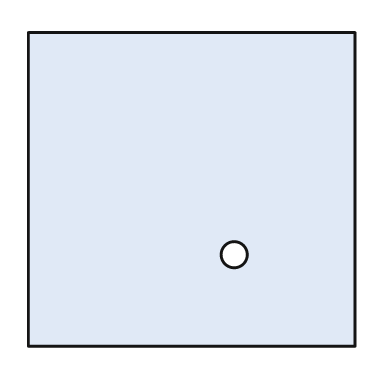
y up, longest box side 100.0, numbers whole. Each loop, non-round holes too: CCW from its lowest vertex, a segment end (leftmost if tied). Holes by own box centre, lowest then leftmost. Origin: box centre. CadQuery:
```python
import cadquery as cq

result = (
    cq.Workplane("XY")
    .moveTo(-50.0, -48.0)
    .lineTo(50.0, -48.0)
    .lineTo(50.0, 48.0)
    .lineTo(-50.0, 48.0)
    .close()
    .moveTo(13.0, -20.0)
    .circle(4.0)
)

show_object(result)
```